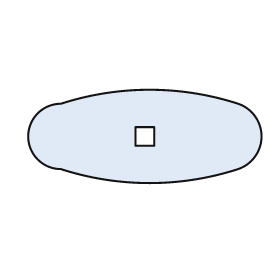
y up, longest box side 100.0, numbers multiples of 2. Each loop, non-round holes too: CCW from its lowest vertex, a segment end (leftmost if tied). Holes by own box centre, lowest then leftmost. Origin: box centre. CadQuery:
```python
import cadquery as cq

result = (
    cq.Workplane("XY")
    .moveTo(-36.0, -14.0)
    .threePointArc((2.0, -20.0), (40.0, -14.0))
    .threePointArc((50.0, 0.0), (40.0, 14.0))
    .threePointArc((2.0, 20.0), (-36.0, 14.0))
    .threePointArc((-50.0, 0.0), (-36.0, -14.0))
    .close()
    .moveTo(-4.0, -4.0)
    .lineTo(4.0, -4.0)
    .lineTo(4.0, 4.0)
    .lineTo(-4.0, 4.0)
    .close()
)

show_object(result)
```